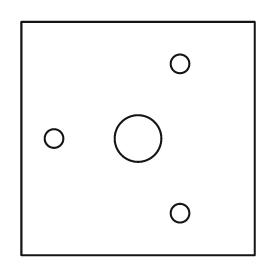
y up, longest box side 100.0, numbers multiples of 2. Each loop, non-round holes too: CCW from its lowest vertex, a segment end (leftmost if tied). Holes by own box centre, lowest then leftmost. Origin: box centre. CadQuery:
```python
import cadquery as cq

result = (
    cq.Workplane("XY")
    .moveTo(-50.0, -50.0)
    .lineTo(50.0, -50.0)
    .lineTo(50.0, 50.0)
    .lineTo(-50.0, 50.0)
    .close()
    .moveTo(18.0, -32.0)
    .circle(4.0)
    .moveTo(-36.0, 0.0)
    .circle(4.0)
    .moveTo(0.0, 0.0)
    .circle(10.0)
    .moveTo(18.0, 32.0)
    .circle(4.0)
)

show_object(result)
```